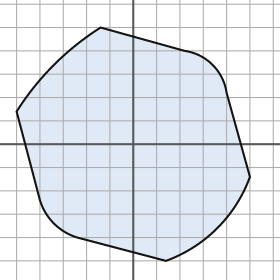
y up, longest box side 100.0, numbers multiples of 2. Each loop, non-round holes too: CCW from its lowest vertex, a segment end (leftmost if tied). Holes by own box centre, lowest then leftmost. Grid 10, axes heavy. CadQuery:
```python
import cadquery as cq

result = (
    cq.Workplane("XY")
    .moveTo(14.0, -50.0)
    .threePointArc((36.0, -36.0), (50.0, -14.0))
    .lineTo(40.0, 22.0)
    .threePointArc((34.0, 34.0), (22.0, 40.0))
    .lineTo(-14.0, 50.0)
    .threePointArc((-34.0, 34.0), (-50.0, 14.0))
    .lineTo(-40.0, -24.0)
    .threePointArc((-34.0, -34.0), (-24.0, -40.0))
    .close()
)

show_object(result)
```